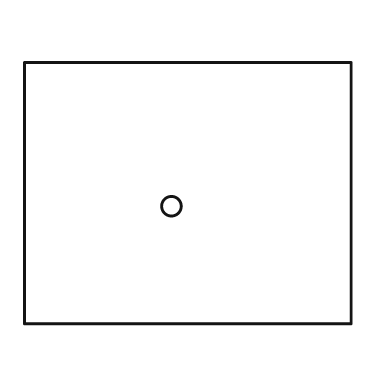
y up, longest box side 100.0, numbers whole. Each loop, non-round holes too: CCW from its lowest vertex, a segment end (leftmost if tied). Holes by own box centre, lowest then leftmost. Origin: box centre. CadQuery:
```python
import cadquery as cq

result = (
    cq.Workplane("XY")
    .moveTo(-50.0, -40.0)
    .lineTo(50.0, -40.0)
    .lineTo(50.0, 40.0)
    .lineTo(-50.0, 40.0)
    .close()
    .moveTo(-5.0, -4.0)
    .circle(3.0)
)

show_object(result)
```